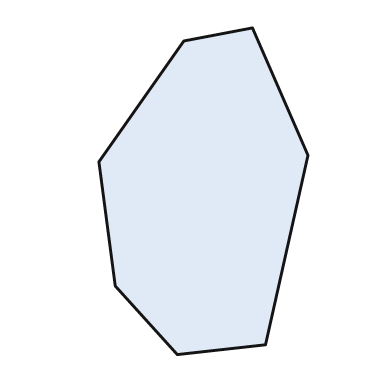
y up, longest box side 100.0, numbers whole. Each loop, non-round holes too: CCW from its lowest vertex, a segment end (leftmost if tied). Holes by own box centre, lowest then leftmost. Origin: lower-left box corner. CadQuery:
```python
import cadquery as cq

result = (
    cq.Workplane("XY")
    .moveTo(24.0, 0.0)
    .lineTo(51.0, 3.0)
    .lineTo(64.0, 61.0)
    .lineTo(47.0, 100.0)
    .lineTo(26.0, 96.0)
    .lineTo(0.0, 59.0)
    .lineTo(5.0, 21.0)
    .close()
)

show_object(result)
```